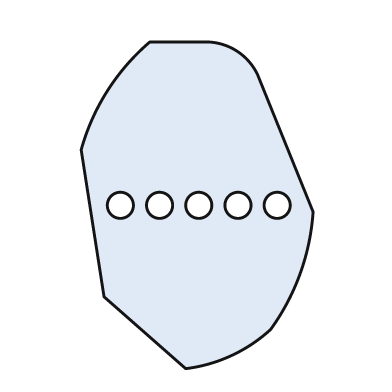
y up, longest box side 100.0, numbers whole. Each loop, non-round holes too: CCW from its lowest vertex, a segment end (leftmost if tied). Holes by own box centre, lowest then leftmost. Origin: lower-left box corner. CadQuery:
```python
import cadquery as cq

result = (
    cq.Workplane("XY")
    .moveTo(32.0, 0.0)
    .threePointArc((46.0, 4.0), (58.0, 12.0))
    .threePointArc((67.0, 29.0), (71.0, 48.0))
    .lineTo(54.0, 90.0)
    .threePointArc((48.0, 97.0), (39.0, 100.0))
    .lineTo(21.0, 100.0)
    .threePointArc((8.0, 85.0), (0.0, 67.0))
    .lineTo(7.0, 22.0)
    .close()
    .moveTo(12.0, 50.0)
    .circle(4.0)
    .moveTo(24.0, 50.0)
    .circle(4.0)
    .moveTo(36.0, 50.0)
    .circle(4.0)
    .moveTo(48.0, 50.0)
    .circle(4.0)
    .moveTo(60.0, 50.0)
    .circle(4.0)
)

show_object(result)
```